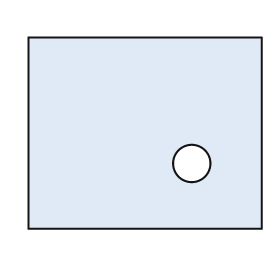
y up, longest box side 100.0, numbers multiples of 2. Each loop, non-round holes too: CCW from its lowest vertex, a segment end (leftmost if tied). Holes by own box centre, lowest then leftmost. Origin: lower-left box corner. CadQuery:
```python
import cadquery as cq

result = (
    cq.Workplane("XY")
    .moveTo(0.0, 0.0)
    .lineTo(100.0, 0.0)
    .lineTo(100.0, 82.0)
    .lineTo(0.0, 82.0)
    .close()
    .moveTo(70.0, 28.0)
    .circle(8.0)
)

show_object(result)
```